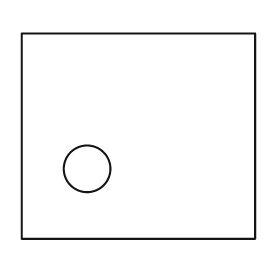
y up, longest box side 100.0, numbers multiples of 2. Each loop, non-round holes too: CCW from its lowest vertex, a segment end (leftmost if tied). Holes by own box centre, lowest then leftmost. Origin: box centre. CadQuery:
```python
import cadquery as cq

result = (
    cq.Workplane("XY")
    .moveTo(-50.0, -44.0)
    .lineTo(50.0, -44.0)
    .lineTo(50.0, 44.0)
    .lineTo(-50.0, 44.0)
    .close()
    .moveTo(-22.0, -14.0)
    .circle(10.0)
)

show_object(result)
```